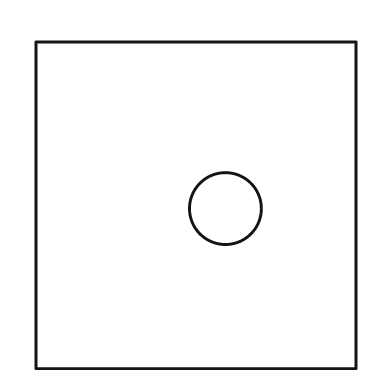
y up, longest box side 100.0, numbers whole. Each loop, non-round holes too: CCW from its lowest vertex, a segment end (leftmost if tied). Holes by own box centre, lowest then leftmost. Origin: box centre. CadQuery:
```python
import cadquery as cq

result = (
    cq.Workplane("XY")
    .moveTo(-49.0, -50.0)
    .lineTo(49.0, -50.0)
    .lineTo(49.0, 50.0)
    .lineTo(-49.0, 50.0)
    .close()
    .moveTo(9.0, -1.0)
    .circle(11.0)
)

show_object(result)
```